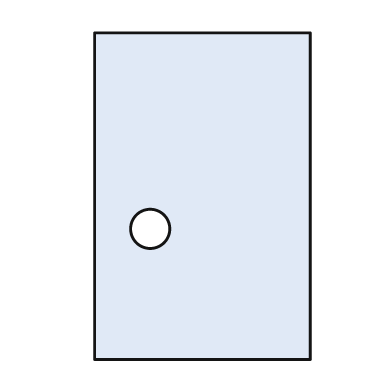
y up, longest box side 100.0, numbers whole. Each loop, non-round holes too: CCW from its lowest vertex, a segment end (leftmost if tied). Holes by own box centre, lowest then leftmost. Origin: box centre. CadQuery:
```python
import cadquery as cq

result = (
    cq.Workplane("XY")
    .moveTo(-33.0, -50.0)
    .lineTo(33.0, -50.0)
    .lineTo(33.0, 50.0)
    .lineTo(-33.0, 50.0)
    .close()
    .moveTo(-16.0, -10.0)
    .circle(6.0)
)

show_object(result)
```